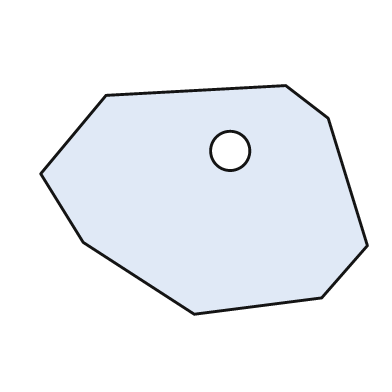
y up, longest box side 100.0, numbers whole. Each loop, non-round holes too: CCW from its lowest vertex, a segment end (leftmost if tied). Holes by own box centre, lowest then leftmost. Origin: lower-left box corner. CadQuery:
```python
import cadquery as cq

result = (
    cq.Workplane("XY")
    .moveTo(47.0, 0.0)
    .lineTo(86.0, 5.0)
    .lineTo(100.0, 21.0)
    .lineTo(88.0, 60.0)
    .lineTo(75.0, 70.0)
    .lineTo(20.0, 67.0)
    .lineTo(0.0, 43.0)
    .lineTo(13.0, 22.0)
    .close()
    .moveTo(58.0, 50.0)
    .circle(6.0)
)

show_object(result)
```